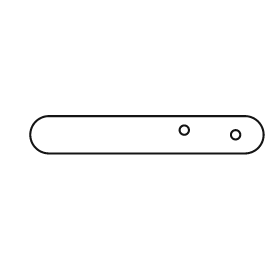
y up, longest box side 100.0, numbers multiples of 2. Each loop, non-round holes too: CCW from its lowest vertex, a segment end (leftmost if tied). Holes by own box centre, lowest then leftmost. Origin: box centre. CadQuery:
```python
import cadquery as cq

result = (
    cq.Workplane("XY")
    .moveTo(-42.0, -8.0)
    .lineTo(42.0, -8.0)
    .threePointArc((50.0, 0.0), (42.0, 8.0))
    .lineTo(-42.0, 8.0)
    .threePointArc((-50.0, 0.0), (-42.0, -8.0))
    .close()
    .moveTo(38.0, 0.0)
    .circle(2.0)
    .moveTo(16.0, 2.0)
    .circle(2.0)
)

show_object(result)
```